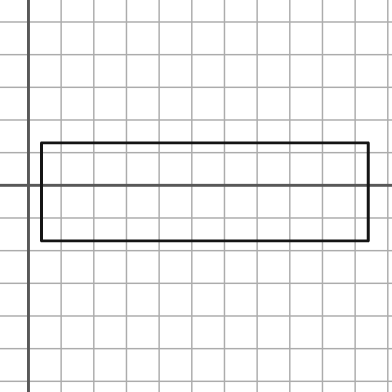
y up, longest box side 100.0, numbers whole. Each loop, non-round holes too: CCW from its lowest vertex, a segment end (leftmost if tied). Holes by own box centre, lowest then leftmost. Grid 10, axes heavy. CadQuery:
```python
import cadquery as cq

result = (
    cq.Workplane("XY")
    .moveTo(4.0, -17.0)
    .lineTo(104.0, -17.0)
    .lineTo(104.0, 13.0)
    .lineTo(4.0, 13.0)
    .close()
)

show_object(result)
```